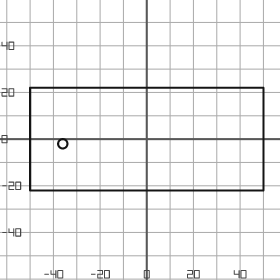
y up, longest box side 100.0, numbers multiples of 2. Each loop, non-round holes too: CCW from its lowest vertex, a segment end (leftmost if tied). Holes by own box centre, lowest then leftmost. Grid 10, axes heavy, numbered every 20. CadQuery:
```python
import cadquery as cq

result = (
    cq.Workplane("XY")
    .moveTo(-50.0, -22.0)
    .lineTo(50.0, -22.0)
    .lineTo(50.0, 22.0)
    .lineTo(-50.0, 22.0)
    .close()
    .moveTo(-36.0, -2.0)
    .circle(2.0)
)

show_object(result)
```